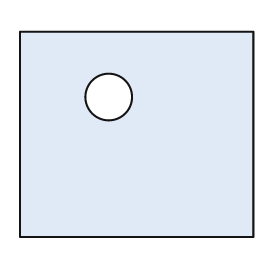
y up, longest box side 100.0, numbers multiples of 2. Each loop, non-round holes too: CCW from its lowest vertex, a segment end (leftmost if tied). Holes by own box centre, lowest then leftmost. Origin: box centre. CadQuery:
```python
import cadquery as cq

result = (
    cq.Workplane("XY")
    .moveTo(-50.0, -44.0)
    .lineTo(50.0, -44.0)
    .lineTo(50.0, 44.0)
    .lineTo(-50.0, 44.0)
    .close()
    .moveTo(-12.0, 16.0)
    .circle(10.0)
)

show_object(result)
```